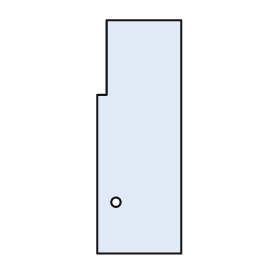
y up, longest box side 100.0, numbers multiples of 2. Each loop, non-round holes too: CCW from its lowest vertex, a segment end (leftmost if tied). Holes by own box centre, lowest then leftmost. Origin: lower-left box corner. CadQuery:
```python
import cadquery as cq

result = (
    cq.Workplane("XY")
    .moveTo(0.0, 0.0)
    .lineTo(36.0, 0.0)
    .lineTo(36.0, 100.0)
    .lineTo(4.0, 100.0)
    .lineTo(4.0, 68.0)
    .lineTo(0.0, 68.0)
    .close()
    .moveTo(8.0, 22.0)
    .circle(2.0)
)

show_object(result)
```